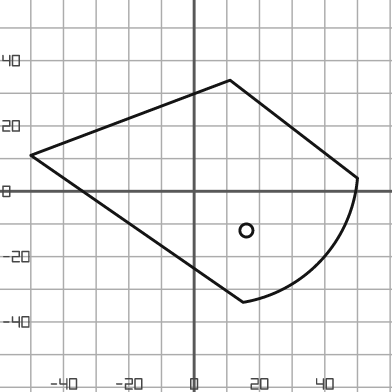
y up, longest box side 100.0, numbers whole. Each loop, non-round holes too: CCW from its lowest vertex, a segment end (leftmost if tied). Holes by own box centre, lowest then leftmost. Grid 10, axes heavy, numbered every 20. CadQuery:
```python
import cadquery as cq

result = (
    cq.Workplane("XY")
    .moveTo(15.0, -34.0)
    .threePointArc((39.0, -21.0), (50.0, 4.0))
    .lineTo(11.0, 34.0)
    .lineTo(-50.0, 11.0)
    .close()
    .moveTo(16.0, -12.0)
    .circle(2.0)
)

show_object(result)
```